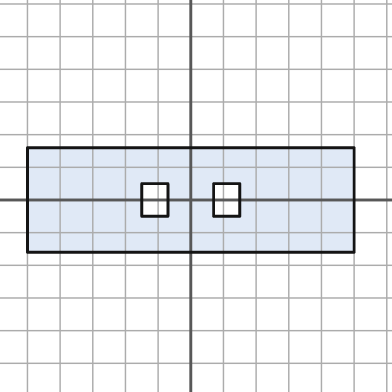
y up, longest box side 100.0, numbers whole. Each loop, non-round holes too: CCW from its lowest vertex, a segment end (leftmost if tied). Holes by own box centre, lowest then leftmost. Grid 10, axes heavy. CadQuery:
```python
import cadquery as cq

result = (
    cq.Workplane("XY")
    .moveTo(-50.0, -16.0)
    .lineTo(50.0, -16.0)
    .lineTo(50.0, 16.0)
    .lineTo(-50.0, 16.0)
    .close()
    .moveTo(-15.0, -5.0)
    .lineTo(-7.0, -5.0)
    .lineTo(-7.0, 5.0)
    .lineTo(-15.0, 5.0)
    .close()
    .moveTo(7.0, -5.0)
    .lineTo(15.0, -5.0)
    .lineTo(15.0, 5.0)
    .lineTo(7.0, 5.0)
    .close()
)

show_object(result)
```